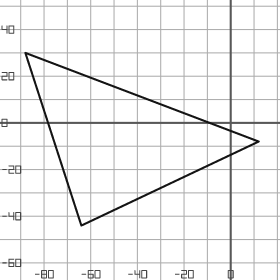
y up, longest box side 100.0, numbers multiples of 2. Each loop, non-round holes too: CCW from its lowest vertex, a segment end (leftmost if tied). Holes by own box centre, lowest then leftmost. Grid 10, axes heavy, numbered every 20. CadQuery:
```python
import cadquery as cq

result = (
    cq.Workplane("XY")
    .moveTo(-64.0, -44.0)
    .lineTo(12.0, -8.0)
    .lineTo(-88.0, 30.0)
    .close()
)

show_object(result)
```